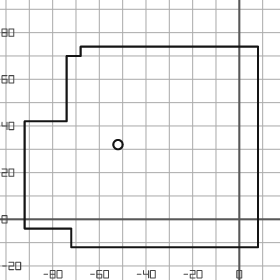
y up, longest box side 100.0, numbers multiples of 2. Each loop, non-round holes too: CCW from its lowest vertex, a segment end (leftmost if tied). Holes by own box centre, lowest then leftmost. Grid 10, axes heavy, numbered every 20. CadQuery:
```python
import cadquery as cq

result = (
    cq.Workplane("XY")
    .moveTo(-72.0, -12.0)
    .lineTo(8.0, -12.0)
    .lineTo(8.0, 74.0)
    .lineTo(-68.0, 74.0)
    .lineTo(-68.0, 70.0)
    .lineTo(-74.0, 70.0)
    .lineTo(-74.0, 42.0)
    .lineTo(-92.0, 42.0)
    .lineTo(-92.0, -4.0)
    .lineTo(-72.0, -4.0)
    .close()
    .moveTo(-52.0, 32.0)
    .circle(2.0)
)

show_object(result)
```